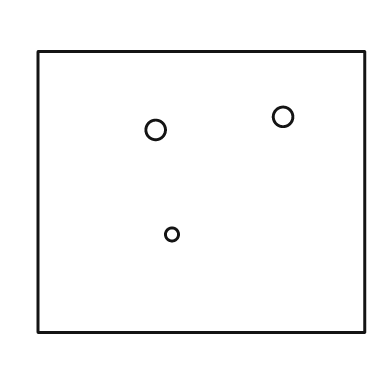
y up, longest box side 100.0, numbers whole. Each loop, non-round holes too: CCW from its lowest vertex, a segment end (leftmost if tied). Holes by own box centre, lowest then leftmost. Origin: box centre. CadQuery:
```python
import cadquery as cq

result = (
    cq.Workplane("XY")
    .moveTo(-50.0, -43.0)
    .lineTo(50.0, -43.0)
    .lineTo(50.0, 43.0)
    .lineTo(-50.0, 43.0)
    .close()
    .moveTo(-9.0, -13.0)
    .circle(2.0)
    .moveTo(-14.0, 19.0)
    .circle(3.0)
    .moveTo(25.0, 23.0)
    .circle(3.0)
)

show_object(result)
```